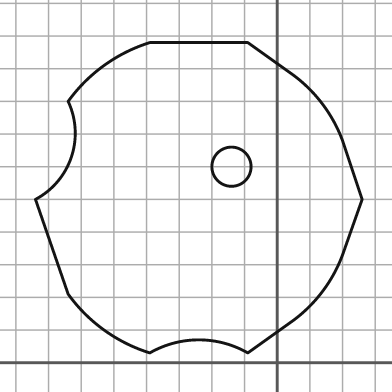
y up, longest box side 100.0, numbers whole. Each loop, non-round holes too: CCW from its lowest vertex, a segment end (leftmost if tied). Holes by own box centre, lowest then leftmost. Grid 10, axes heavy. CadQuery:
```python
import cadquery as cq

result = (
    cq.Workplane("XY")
    .moveTo(-39.0, 3.0)
    .threePointArc((-24.0, 7.0), (-9.0, 3.0))
    .lineTo(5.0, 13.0)
    .threePointArc((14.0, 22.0), (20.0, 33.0))
    .lineTo(26.0, 50.0)
    .lineTo(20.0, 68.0)
    .threePointArc((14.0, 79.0), (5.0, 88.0))
    .lineTo(-9.0, 98.0)
    .lineTo(-39.0, 98.0)
    .threePointArc((-53.0, 91.0), (-64.0, 80.0))
    .threePointArc((-63.0, 63.0), (-74.0, 50.0))
    .lineTo(-64.0, 21.0)
    .threePointArc((-53.0, 10.0), (-39.0, 3.0))
    .close()
    .moveTo(-14.0, 60.0)
    .circle(6.0)
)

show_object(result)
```